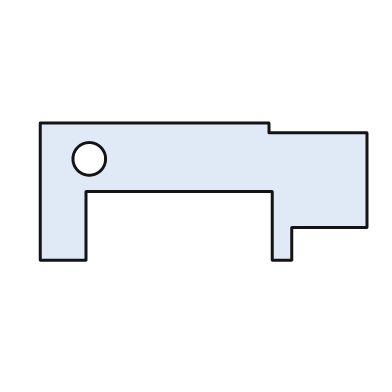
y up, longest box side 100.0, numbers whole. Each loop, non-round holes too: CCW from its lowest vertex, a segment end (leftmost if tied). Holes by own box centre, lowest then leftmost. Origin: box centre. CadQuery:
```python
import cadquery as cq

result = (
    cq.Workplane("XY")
    .moveTo(-50.0, -21.0)
    .lineTo(-36.0, -21.0)
    .lineTo(-36.0, 0.0)
    .lineTo(21.0, 0.0)
    .lineTo(21.0, -21.0)
    .lineTo(27.0, -21.0)
    .lineTo(27.0, -11.0)
    .lineTo(50.0, -11.0)
    .lineTo(50.0, 18.0)
    .lineTo(20.0, 18.0)
    .lineTo(20.0, 21.0)
    .lineTo(-50.0, 21.0)
    .close()
    .moveTo(-35.0, 10.0)
    .circle(5.0)
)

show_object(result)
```